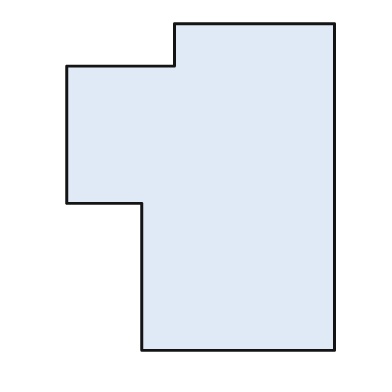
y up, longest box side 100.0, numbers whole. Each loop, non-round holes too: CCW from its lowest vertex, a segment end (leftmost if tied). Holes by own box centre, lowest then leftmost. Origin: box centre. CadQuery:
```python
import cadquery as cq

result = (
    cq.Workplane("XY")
    .moveTo(-18.0, -50.0)
    .lineTo(41.0, -50.0)
    .lineTo(41.0, 50.0)
    .lineTo(-8.0, 50.0)
    .lineTo(-8.0, 37.0)
    .lineTo(-41.0, 37.0)
    .lineTo(-41.0, -5.0)
    .lineTo(-18.0, -5.0)
    .close()
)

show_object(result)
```